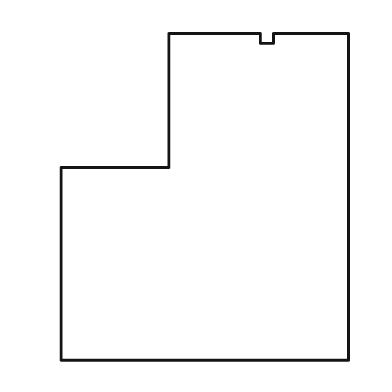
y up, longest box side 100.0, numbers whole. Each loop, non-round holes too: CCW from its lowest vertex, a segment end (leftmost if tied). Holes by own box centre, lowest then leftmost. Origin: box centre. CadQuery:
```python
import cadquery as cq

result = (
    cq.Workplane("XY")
    .moveTo(-44.0, -50.0)
    .lineTo(44.0, -50.0)
    .lineTo(44.0, 50.0)
    .lineTo(21.0, 50.0)
    .lineTo(21.0, 47.0)
    .lineTo(17.0, 47.0)
    .lineTo(17.0, 50.0)
    .lineTo(-11.0, 50.0)
    .lineTo(-11.0, 9.0)
    .lineTo(-44.0, 9.0)
    .close()
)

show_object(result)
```